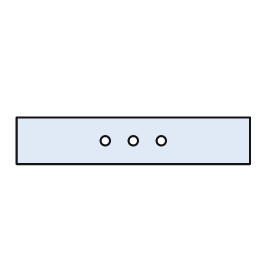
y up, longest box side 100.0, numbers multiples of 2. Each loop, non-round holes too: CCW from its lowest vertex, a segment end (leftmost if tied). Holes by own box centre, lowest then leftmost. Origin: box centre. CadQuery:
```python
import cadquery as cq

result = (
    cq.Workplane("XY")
    .moveTo(-50.0, -10.0)
    .lineTo(50.0, -10.0)
    .lineTo(50.0, 10.0)
    .lineTo(-50.0, 10.0)
    .close()
    .moveTo(-12.0, 0.0)
    .circle(2.0)
    .moveTo(0.0, 0.0)
    .circle(2.0)
    .moveTo(12.0, 0.0)
    .circle(2.0)
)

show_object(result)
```